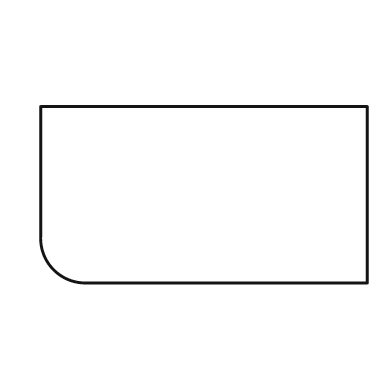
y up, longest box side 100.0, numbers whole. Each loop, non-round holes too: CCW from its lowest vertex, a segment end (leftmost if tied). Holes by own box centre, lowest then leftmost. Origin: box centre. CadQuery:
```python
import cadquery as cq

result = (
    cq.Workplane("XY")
    .moveTo(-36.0, -27.0)
    .lineTo(50.0, -27.0)
    .lineTo(50.0, 27.0)
    .lineTo(-50.0, 27.0)
    .lineTo(-50.0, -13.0)
    .threePointArc((-46.0, -23.0), (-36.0, -27.0))
    .close()
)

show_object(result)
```